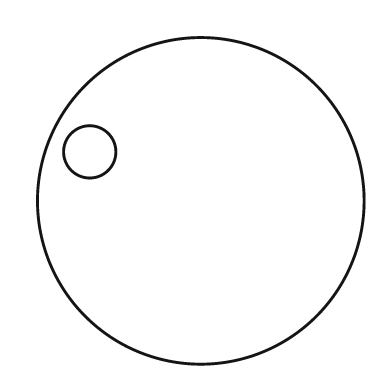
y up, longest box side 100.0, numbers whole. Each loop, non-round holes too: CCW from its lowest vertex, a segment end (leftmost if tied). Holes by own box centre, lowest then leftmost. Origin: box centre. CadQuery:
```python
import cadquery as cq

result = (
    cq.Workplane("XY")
    .moveTo(0.0, 0.0)
    .circle(50.0)
    .moveTo(-34.0, 15.0)
    .circle(8.0)
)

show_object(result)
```